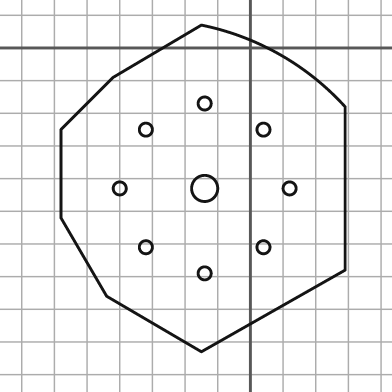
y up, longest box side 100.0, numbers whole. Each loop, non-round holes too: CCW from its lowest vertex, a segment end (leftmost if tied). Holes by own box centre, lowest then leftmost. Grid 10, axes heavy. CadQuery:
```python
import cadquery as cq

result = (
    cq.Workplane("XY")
    .moveTo(-15.0, -93.0)
    .lineTo(29.0, -68.0)
    .lineTo(29.0, -18.0)
    .threePointArc((9.0, -2.0), (-15.0, 7.0))
    .lineTo(-42.0, -9.0)
    .lineTo(-58.0, -25.0)
    .lineTo(-58.0, -52.0)
    .lineTo(-44.0, -76.0)
    .close()
    .moveTo(-14.0, -69.0)
    .circle(2.0)
    .moveTo(-32.0, -61.0)
    .circle(2.0)
    .moveTo(4.0, -61.0)
    .circle(2.0)
    .moveTo(-40.0, -43.0)
    .circle(2.0)
    .moveTo(-14.0, -43.0)
    .circle(4.0)
    .moveTo(12.0, -43.0)
    .circle(2.0)
    .moveTo(-32.0, -25.0)
    .circle(2.0)
    .moveTo(4.0, -25.0)
    .circle(2.0)
    .moveTo(-14.0, -17.0)
    .circle(2.0)
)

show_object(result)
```